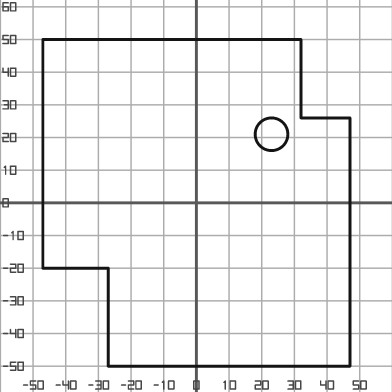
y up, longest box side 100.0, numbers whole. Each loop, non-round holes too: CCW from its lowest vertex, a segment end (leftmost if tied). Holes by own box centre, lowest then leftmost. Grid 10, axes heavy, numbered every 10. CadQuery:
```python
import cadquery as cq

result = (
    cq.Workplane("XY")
    .moveTo(-27.0, -50.0)
    .lineTo(47.0, -50.0)
    .lineTo(47.0, 26.0)
    .lineTo(32.0, 26.0)
    .lineTo(32.0, 50.0)
    .lineTo(-47.0, 50.0)
    .lineTo(-47.0, -20.0)
    .lineTo(-27.0, -20.0)
    .close()
    .moveTo(23.0, 21.0)
    .circle(5.0)
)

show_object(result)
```